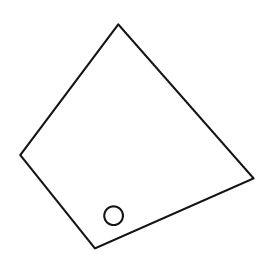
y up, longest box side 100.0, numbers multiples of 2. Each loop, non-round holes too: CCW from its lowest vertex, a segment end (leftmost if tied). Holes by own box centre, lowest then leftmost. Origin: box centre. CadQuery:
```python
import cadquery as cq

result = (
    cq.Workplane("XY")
    .moveTo(-18.0, -48.0)
    .lineTo(50.0, -18.0)
    .lineTo(-8.0, 48.0)
    .lineTo(-50.0, -8.0)
    .close()
    .moveTo(-10.0, -34.0)
    .circle(4.0)
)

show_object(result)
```